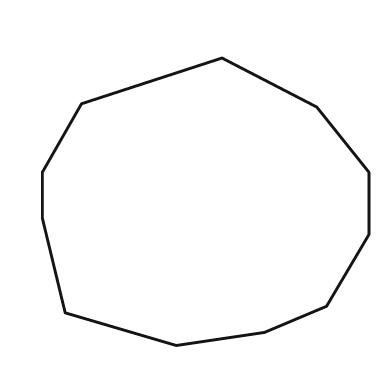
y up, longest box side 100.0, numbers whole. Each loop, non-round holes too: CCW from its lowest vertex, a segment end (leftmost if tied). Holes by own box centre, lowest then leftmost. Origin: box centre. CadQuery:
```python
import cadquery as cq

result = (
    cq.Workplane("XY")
    .moveTo(-9.0, -44.0)
    .lineTo(18.0, -40.0)
    .lineTo(37.0, -32.0)
    .lineTo(50.0, -10.0)
    .lineTo(50.0, 9.0)
    .lineTo(34.0, 29.0)
    .lineTo(5.0, 44.0)
    .lineTo(-38.0, 30.0)
    .lineTo(-50.0, 9.0)
    .lineTo(-50.0, -5.0)
    .lineTo(-43.0, -34.0)
    .close()
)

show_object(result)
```